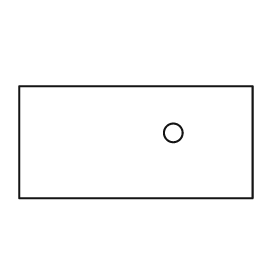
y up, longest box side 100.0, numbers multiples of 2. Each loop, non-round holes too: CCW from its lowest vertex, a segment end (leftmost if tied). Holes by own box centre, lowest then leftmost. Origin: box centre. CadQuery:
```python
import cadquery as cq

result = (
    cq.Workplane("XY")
    .moveTo(-50.0, -24.0)
    .lineTo(50.0, -24.0)
    .lineTo(50.0, 24.0)
    .lineTo(-50.0, 24.0)
    .close()
    .moveTo(16.0, 4.0)
    .circle(4.0)
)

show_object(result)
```